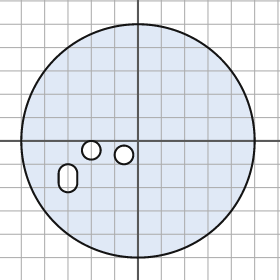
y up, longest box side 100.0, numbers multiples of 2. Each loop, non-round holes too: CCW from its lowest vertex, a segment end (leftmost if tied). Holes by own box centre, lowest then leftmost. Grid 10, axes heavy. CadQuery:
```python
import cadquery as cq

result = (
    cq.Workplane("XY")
    .moveTo(0.0, 0.0)
    .circle(50.0)
    .moveTo(-34.0, -18.0)
    .threePointArc((-30.0, -22.0), (-26.0, -18.0))
    .lineTo(-26.0, -14.0)
    .threePointArc((-30.0, -10.0), (-34.0, -14.0))
    .close()
    .moveTo(-6.0, -6.0)
    .circle(4.0)
    .moveTo(-20.0, -4.0)
    .circle(4.0)
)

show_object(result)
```